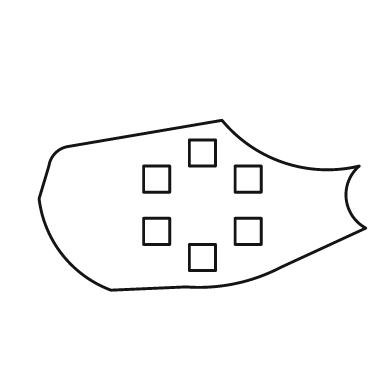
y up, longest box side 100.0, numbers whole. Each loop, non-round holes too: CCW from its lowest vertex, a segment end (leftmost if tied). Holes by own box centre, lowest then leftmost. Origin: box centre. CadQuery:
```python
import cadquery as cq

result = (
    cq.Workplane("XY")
    .moveTo(-28.0, -26.0)
    .lineTo(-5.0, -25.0)
    .threePointArc((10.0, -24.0), (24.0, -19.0))
    .lineTo(50.0, -7.0)
    .threePointArc((44.0, 2.0), (48.0, 12.0))
    .threePointArc((25.0, 13.0), (6.0, 26.0))
    .lineTo(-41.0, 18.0)
    .threePointArc((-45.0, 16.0), (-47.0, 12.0))
    .lineTo(-50.0, 2.0)
    .threePointArc((-43.0, -15.0), (-28.0, -26.0))
    .close()
    .moveTo(-4.0, -20.0)
    .lineTo(4.0, -20.0)
    .lineTo(4.0, -12.0)
    .lineTo(-4.0, -12.0)
    .close()
    .moveTo(-18.0, -12.0)
    .lineTo(-10.0, -12.0)
    .lineTo(-10.0, -4.0)
    .lineTo(-18.0, -4.0)
    .close()
    .moveTo(10.0, -12.0)
    .lineTo(18.0, -12.0)
    .lineTo(18.0, -4.0)
    .lineTo(10.0, -4.0)
    .close()
    .moveTo(-18.0, 4.0)
    .lineTo(-10.0, 4.0)
    .lineTo(-10.0, 12.0)
    .lineTo(-18.0, 12.0)
    .close()
    .moveTo(10.0, 4.0)
    .lineTo(18.0, 4.0)
    .lineTo(18.0, 12.0)
    .lineTo(10.0, 12.0)
    .close()
    .moveTo(-4.0, 12.0)
    .lineTo(4.0, 12.0)
    .lineTo(4.0, 20.0)
    .lineTo(-4.0, 20.0)
    .close()
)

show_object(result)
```